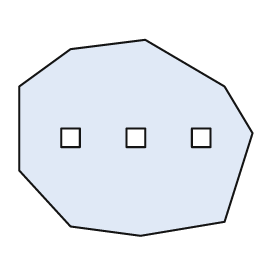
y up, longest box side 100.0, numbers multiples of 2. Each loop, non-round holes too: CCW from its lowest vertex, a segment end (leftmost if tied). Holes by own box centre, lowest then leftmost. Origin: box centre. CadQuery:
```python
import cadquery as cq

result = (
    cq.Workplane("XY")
    .moveTo(2.0, -42.0)
    .lineTo(38.0, -36.0)
    .lineTo(50.0, 2.0)
    .lineTo(38.0, 22.0)
    .lineTo(4.0, 42.0)
    .lineTo(-28.0, 38.0)
    .lineTo(-50.0, 22.0)
    .lineTo(-50.0, -14.0)
    .lineTo(-28.0, -38.0)
    .close()
    .moveTo(-32.0, -4.0)
    .lineTo(-24.0, -4.0)
    .lineTo(-24.0, 4.0)
    .lineTo(-32.0, 4.0)
    .close()
    .moveTo(-4.0, -4.0)
    .lineTo(4.0, -4.0)
    .lineTo(4.0, 4.0)
    .lineTo(-4.0, 4.0)
    .close()
    .moveTo(24.0, -4.0)
    .lineTo(32.0, -4.0)
    .lineTo(32.0, 4.0)
    .lineTo(24.0, 4.0)
    .close()
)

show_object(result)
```